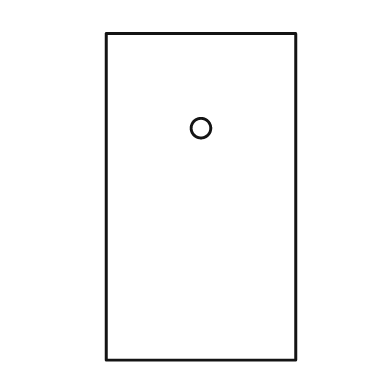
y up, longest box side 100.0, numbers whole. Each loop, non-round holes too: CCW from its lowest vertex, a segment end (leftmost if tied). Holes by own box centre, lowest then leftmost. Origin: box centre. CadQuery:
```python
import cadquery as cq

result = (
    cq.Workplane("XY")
    .moveTo(-29.0, -50.0)
    .lineTo(29.0, -50.0)
    .lineTo(29.0, 50.0)
    .lineTo(-29.0, 50.0)
    .close()
    .moveTo(0.0, 21.0)
    .circle(3.0)
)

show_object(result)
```